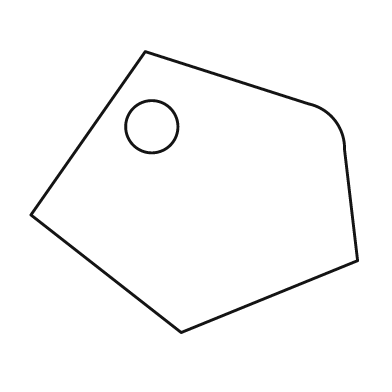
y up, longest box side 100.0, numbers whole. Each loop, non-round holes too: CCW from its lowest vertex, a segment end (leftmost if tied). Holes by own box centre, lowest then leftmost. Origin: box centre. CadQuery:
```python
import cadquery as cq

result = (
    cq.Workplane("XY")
    .moveTo(-4.0, -43.0)
    .lineTo(50.0, -21.0)
    .lineTo(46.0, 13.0)
    .threePointArc((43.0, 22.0), (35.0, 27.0))
    .lineTo(-15.0, 43.0)
    .lineTo(-50.0, -7.0)
    .close()
    .moveTo(-13.0, 20.0)
    .circle(8.0)
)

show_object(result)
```